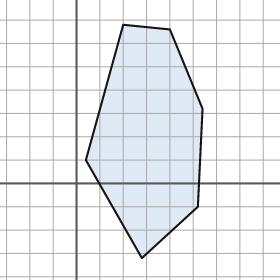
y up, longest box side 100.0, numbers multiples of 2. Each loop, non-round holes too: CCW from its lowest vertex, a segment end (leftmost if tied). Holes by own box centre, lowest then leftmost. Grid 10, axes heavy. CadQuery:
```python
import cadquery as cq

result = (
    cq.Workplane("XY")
    .moveTo(28.0, -32.0)
    .lineTo(52.0, -10.0)
    .lineTo(54.0, 32.0)
    .lineTo(40.0, 66.0)
    .lineTo(20.0, 68.0)
    .lineTo(4.0, 10.0)
    .close()
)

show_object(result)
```